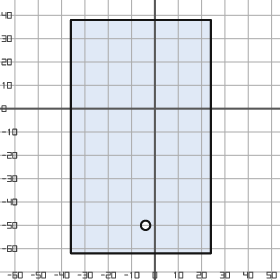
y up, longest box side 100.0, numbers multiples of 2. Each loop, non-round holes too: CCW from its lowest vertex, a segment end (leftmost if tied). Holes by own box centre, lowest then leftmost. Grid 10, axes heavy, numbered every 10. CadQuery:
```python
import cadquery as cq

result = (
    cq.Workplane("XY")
    .moveTo(-36.0, -62.0)
    .lineTo(24.0, -62.0)
    .lineTo(24.0, 38.0)
    .lineTo(-36.0, 38.0)
    .close()
    .moveTo(-4.0, -50.0)
    .circle(2.0)
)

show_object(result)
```